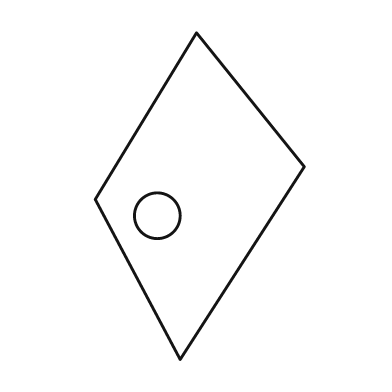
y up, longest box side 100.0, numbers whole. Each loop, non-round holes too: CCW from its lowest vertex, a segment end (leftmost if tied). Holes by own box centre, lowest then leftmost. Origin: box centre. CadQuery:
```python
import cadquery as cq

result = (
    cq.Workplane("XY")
    .moveTo(-6.0, -50.0)
    .lineTo(32.0, 9.0)
    .lineTo(-1.0, 50.0)
    .lineTo(-32.0, -1.0)
    .close()
    .moveTo(-13.0, -6.0)
    .circle(7.0)
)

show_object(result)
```